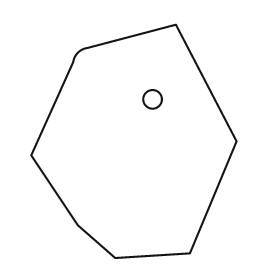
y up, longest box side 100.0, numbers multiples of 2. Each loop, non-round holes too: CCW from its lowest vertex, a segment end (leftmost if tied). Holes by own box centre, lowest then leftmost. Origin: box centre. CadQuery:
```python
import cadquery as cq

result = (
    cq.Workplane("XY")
    .moveTo(-8.0, -50.0)
    .lineTo(24.0, -48.0)
    .lineTo(44.0, 0.0)
    .lineTo(18.0, 50.0)
    .lineTo(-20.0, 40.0)
    .threePointArc((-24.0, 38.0), (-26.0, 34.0))
    .lineTo(-44.0, -6.0)
    .lineTo(-24.0, -36.0)
    .close()
    .moveTo(8.0, 18.0)
    .circle(4.0)
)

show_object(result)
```